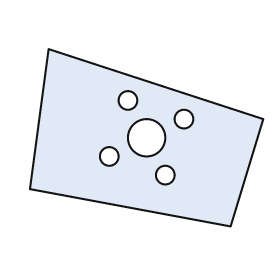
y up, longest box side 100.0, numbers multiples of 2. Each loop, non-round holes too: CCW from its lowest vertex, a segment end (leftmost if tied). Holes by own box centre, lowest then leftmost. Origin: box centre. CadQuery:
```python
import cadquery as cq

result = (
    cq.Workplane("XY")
    .moveTo(36.0, -38.0)
    .lineTo(50.0, 8.0)
    .lineTo(-42.0, 38.0)
    .lineTo(-50.0, -22.0)
    .close()
    .moveTo(8.0, -16.0)
    .circle(4.0)
    .moveTo(-16.0, -8.0)
    .circle(4.0)
    .moveTo(0.0, 0.0)
    .circle(8.0)
    .moveTo(16.0, 8.0)
    .circle(4.0)
    .moveTo(-8.0, 16.0)
    .circle(4.0)
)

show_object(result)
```